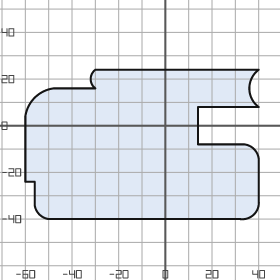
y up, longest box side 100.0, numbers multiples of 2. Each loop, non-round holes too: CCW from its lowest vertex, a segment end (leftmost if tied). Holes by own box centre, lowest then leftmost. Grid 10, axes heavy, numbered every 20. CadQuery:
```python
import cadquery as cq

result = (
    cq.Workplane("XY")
    .moveTo(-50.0, -40.0)
    .lineTo(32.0, -40.0)
    .threePointArc((38.0, -38.0), (40.0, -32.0))
    .lineTo(40.0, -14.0)
    .threePointArc((38.0, -10.0), (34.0, -8.0))
    .lineTo(14.0, -8.0)
    .lineTo(14.0, 8.0)
    .lineTo(40.0, 8.0)
    .threePointArc((36.0, 16.0), (40.0, 24.0))
    .lineTo(-30.0, 24.0)
    .threePointArc((-32.0, 20.0), (-30.0, 16.0))
    .lineTo(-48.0, 16.0)
    .threePointArc((-56.0, 12.0), (-60.0, 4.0))
    .lineTo(-60.0, -24.0)
    .lineTo(-56.0, -24.0)
    .lineTo(-56.0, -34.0)
    .threePointArc((-54.0, -38.0), (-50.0, -40.0))
    .close()
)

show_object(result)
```